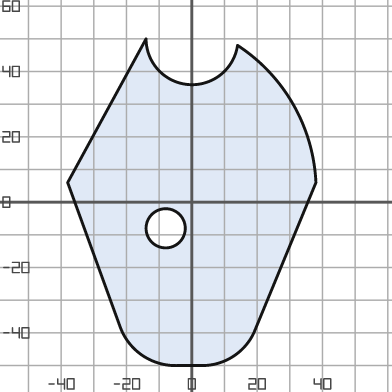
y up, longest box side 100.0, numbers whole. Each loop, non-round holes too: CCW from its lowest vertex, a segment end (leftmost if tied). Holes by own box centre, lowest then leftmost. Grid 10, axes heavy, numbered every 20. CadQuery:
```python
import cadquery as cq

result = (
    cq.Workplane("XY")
    .moveTo(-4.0, -50.0)
    .lineTo(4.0, -50.0)
    .threePointArc((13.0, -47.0), (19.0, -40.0))
    .lineTo(38.0, 6.0)
    .threePointArc((31.0, 30.0), (14.0, 48.0))
    .threePointArc((-1.0, 36.0), (-14.0, 50.0))
    .lineTo(-38.0, 6.0)
    .lineTo(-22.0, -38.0)
    .threePointArc((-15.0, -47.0), (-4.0, -50.0))
    .close()
    .moveTo(-8.0, -8.0)
    .circle(6.0)
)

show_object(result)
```